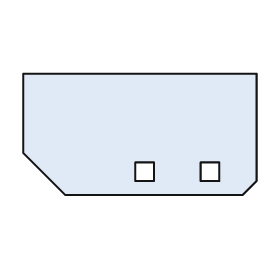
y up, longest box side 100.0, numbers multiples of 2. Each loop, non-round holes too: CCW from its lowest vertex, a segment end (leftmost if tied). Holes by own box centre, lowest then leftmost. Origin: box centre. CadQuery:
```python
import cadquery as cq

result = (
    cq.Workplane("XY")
    .moveTo(-32.0, -26.0)
    .lineTo(44.0, -26.0)
    .lineTo(50.0, -20.0)
    .lineTo(50.0, 26.0)
    .lineTo(-50.0, 26.0)
    .lineTo(-50.0, -8.0)
    .close()
    .moveTo(-2.0, -20.0)
    .lineTo(6.0, -20.0)
    .lineTo(6.0, -12.0)
    .lineTo(-2.0, -12.0)
    .close()
    .moveTo(26.0, -20.0)
    .lineTo(34.0, -20.0)
    .lineTo(34.0, -12.0)
    .lineTo(26.0, -12.0)
    .close()
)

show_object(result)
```